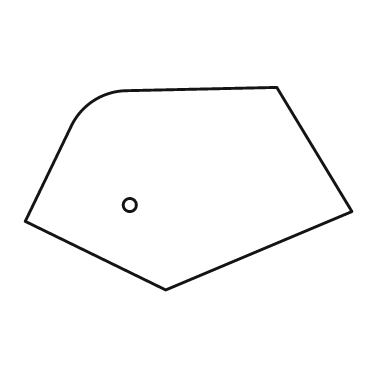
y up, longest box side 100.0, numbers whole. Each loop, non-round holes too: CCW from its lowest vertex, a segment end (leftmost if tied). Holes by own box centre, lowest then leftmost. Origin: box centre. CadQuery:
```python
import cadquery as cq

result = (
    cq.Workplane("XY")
    .moveTo(-7.0, -31.0)
    .lineTo(50.0, -7.0)
    .lineTo(27.0, 31.0)
    .lineTo(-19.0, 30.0)
    .threePointArc((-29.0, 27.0), (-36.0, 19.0))
    .lineTo(-50.0, -10.0)
    .close()
    .moveTo(-18.0, -5.0)
    .circle(2.0)
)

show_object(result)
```